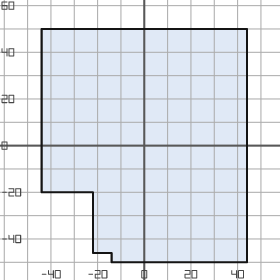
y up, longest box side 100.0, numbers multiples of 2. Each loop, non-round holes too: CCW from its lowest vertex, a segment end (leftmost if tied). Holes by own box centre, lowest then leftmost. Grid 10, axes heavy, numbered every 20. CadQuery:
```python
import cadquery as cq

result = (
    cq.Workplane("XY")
    .moveTo(-14.0, -50.0)
    .lineTo(44.0, -50.0)
    .lineTo(44.0, 50.0)
    .lineTo(-44.0, 50.0)
    .lineTo(-44.0, -20.0)
    .lineTo(-22.0, -20.0)
    .lineTo(-22.0, -46.0)
    .lineTo(-14.0, -46.0)
    .close()
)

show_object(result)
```